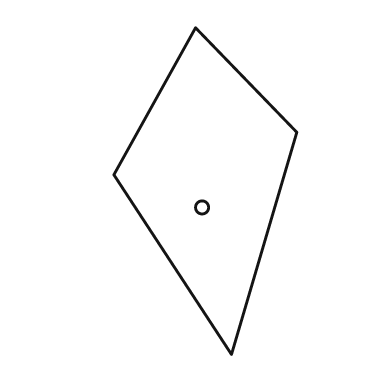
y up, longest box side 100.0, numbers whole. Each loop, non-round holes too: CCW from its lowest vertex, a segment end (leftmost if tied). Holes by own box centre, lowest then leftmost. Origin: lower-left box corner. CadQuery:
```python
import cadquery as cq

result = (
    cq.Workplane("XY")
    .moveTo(36.0, 0.0)
    .lineTo(56.0, 68.0)
    .lineTo(25.0, 100.0)
    .lineTo(0.0, 55.0)
    .close()
    .moveTo(27.0, 45.0)
    .circle(2.0)
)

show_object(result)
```